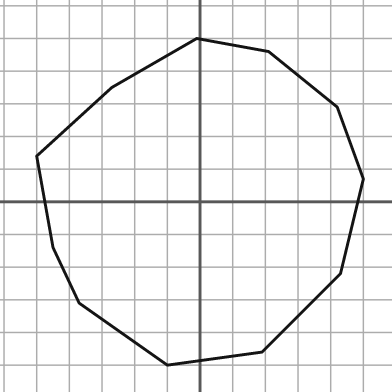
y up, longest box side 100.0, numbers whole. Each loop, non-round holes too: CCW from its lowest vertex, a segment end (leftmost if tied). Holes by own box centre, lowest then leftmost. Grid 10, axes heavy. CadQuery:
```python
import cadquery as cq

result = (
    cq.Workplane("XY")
    .moveTo(-10.0, -50.0)
    .lineTo(19.0, -46.0)
    .lineTo(43.0, -22.0)
    .lineTo(50.0, 7.0)
    .lineTo(42.0, 29.0)
    .lineTo(21.0, 46.0)
    .lineTo(-1.0, 50.0)
    .lineTo(-27.0, 35.0)
    .lineTo(-50.0, 14.0)
    .lineTo(-45.0, -14.0)
    .lineTo(-37.0, -31.0)
    .close()
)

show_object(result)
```